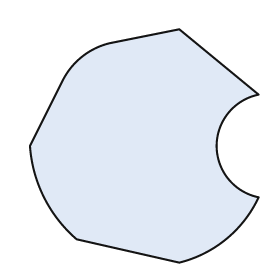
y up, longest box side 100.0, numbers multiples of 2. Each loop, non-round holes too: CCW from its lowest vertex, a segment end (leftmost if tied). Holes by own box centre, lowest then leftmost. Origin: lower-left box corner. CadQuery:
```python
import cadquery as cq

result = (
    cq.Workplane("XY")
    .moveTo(64.0, 0.0)
    .threePointArc((84.0, 10.0), (98.0, 28.0))
    .threePointArc((80.0, 50.0), (98.0, 72.0))
    .lineTo(64.0, 100.0)
    .lineTo(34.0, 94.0)
    .threePointArc((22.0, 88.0), (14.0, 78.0))
    .lineTo(0.0, 50.0)
    .threePointArc((6.0, 28.0), (20.0, 10.0))
    .close()
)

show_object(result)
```